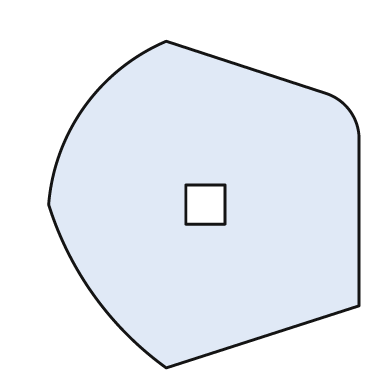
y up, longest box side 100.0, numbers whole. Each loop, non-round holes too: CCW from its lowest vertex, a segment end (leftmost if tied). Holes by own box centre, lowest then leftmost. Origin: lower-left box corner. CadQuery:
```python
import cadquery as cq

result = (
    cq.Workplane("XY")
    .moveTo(36.0, 0.0)
    .lineTo(95.0, 19.0)
    .lineTo(95.0, 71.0)
    .threePointArc((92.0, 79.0), (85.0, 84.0))
    .lineTo(36.0, 100.0)
    .threePointArc((11.0, 80.0), (0.0, 50.0))
    .threePointArc((14.0, 22.0), (36.0, 0.0))
    .close()
    .moveTo(42.0, 44.0)
    .lineTo(54.0, 44.0)
    .lineTo(54.0, 56.0)
    .lineTo(42.0, 56.0)
    .close()
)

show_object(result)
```